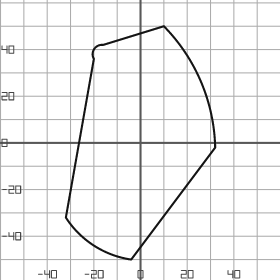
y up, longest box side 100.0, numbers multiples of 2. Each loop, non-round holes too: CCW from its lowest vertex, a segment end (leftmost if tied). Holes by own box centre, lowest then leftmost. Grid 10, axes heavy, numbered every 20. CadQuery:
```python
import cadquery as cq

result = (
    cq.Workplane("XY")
    .moveTo(-4.0, -50.0)
    .lineTo(32.0, -2.0)
    .threePointArc((26.0, 26.0), (10.0, 50.0))
    .lineTo(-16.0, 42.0)
    .threePointArc((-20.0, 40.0), (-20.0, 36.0))
    .lineTo(-32.0, -32.0)
    .threePointArc((-20.0, -44.0), (-4.0, -50.0))
    .close()
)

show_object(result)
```